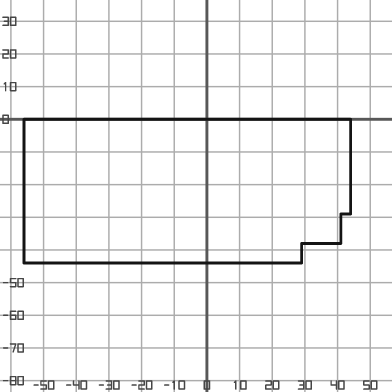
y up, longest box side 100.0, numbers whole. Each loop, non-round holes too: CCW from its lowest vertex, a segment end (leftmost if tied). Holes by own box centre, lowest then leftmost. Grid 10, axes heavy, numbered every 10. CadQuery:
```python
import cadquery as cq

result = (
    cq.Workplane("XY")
    .moveTo(-56.0, -44.0)
    .lineTo(29.0, -44.0)
    .lineTo(29.0, -38.0)
    .lineTo(41.0, -38.0)
    .lineTo(41.0, -29.0)
    .lineTo(44.0, -29.0)
    .lineTo(44.0, 0.0)
    .lineTo(-56.0, 0.0)
    .close()
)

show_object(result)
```